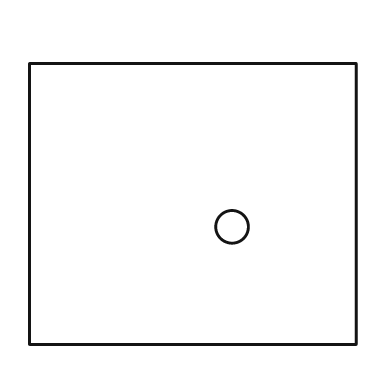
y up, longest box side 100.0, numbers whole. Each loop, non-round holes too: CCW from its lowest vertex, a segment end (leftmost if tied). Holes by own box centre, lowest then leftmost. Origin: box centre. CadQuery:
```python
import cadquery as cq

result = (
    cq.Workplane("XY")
    .moveTo(-50.0, -43.0)
    .lineTo(50.0, -43.0)
    .lineTo(50.0, 43.0)
    .lineTo(-50.0, 43.0)
    .close()
    .moveTo(12.0, -7.0)
    .circle(5.0)
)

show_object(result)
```